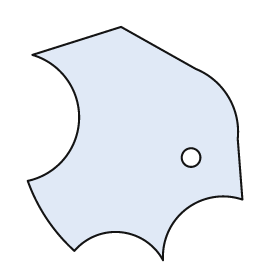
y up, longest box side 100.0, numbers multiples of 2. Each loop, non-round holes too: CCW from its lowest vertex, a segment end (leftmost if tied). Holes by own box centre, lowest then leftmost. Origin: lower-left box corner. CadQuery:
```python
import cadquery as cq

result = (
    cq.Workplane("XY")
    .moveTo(58.0, 0.0)
    .threePointArc((68.0, 22.0), (92.0, 26.0))
    .lineTo(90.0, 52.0)
    .threePointArc((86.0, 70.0), (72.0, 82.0))
    .lineTo(40.0, 100.0)
    .lineTo(2.0, 88.0)
    .threePointArc((22.0, 60.0), (0.0, 34.0))
    .threePointArc((8.0, 18.0), (20.0, 4.0))
    .threePointArc((40.0, 12.0), (58.0, 0.0))
    .close()
    .moveTo(70.0, 44.0)
    .circle(4.0)
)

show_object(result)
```